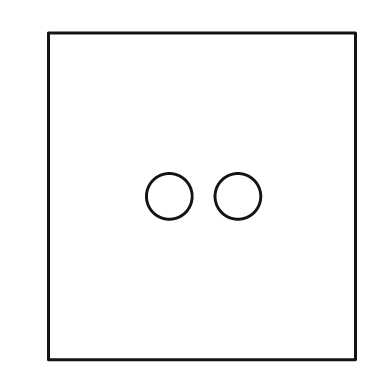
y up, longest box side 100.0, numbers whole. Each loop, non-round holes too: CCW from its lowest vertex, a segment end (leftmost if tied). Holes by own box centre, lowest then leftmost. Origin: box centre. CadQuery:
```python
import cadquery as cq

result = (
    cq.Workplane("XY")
    .moveTo(-47.0, -50.0)
    .lineTo(47.0, -50.0)
    .lineTo(47.0, 50.0)
    .lineTo(-47.0, 50.0)
    .close()
    .moveTo(-10.0, 0.0)
    .circle(7.0)
    .moveTo(11.0, 0.0)
    .circle(7.0)
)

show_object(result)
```